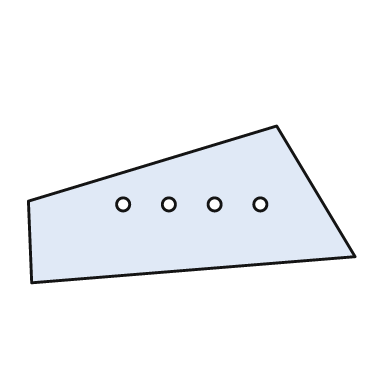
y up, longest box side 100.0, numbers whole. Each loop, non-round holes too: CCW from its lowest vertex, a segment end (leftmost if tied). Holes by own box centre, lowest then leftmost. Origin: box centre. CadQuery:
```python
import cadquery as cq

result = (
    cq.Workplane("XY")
    .moveTo(-49.0, -24.0)
    .lineTo(50.0, -16.0)
    .lineTo(26.0, 24.0)
    .lineTo(-50.0, 1.0)
    .close()
    .moveTo(-21.0, 0.0)
    .circle(2.0)
    .moveTo(-7.0, 0.0)
    .circle(2.0)
    .moveTo(7.0, 0.0)
    .circle(2.0)
    .moveTo(21.0, 0.0)
    .circle(2.0)
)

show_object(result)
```